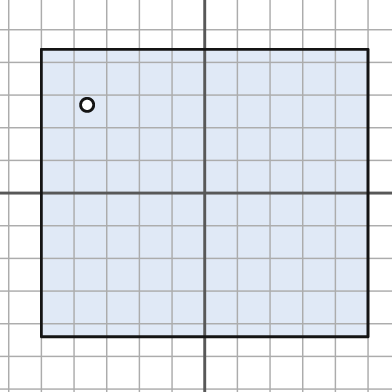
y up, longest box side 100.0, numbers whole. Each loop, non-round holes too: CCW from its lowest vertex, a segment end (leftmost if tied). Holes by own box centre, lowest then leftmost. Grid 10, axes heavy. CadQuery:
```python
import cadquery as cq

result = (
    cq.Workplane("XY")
    .moveTo(-50.0, -44.0)
    .lineTo(50.0, -44.0)
    .lineTo(50.0, 44.0)
    .lineTo(-50.0, 44.0)
    .close()
    .moveTo(-36.0, 27.0)
    .circle(2.0)
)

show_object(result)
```